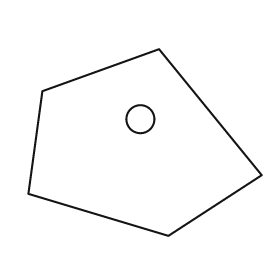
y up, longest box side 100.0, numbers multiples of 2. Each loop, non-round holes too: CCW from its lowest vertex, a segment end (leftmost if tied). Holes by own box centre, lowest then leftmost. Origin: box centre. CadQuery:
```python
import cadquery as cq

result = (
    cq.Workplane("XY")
    .moveTo(10.0, -40.0)
    .lineTo(50.0, -14.0)
    .lineTo(6.0, 40.0)
    .lineTo(-44.0, 22.0)
    .lineTo(-50.0, -22.0)
    .close()
    .moveTo(-2.0, 10.0)
    .circle(6.0)
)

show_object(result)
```